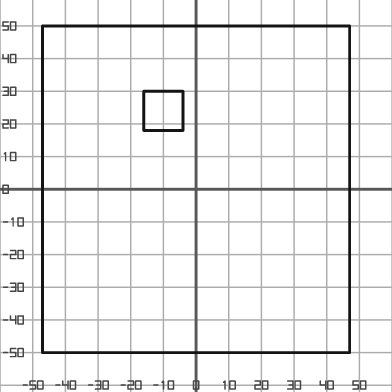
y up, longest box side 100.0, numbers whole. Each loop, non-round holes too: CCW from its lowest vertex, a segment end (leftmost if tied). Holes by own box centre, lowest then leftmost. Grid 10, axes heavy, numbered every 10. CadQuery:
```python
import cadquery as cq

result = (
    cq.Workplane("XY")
    .moveTo(-47.0, -50.0)
    .lineTo(47.0, -50.0)
    .lineTo(47.0, 50.0)
    .lineTo(-47.0, 50.0)
    .close()
    .moveTo(-16.0, 18.0)
    .lineTo(-4.0, 18.0)
    .lineTo(-4.0, 30.0)
    .lineTo(-16.0, 30.0)
    .close()
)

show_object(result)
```